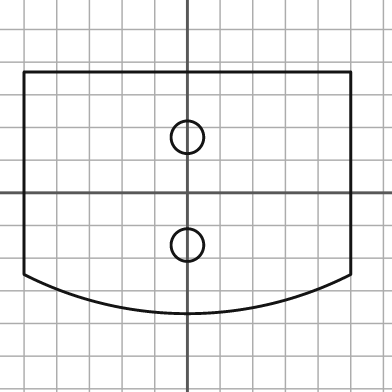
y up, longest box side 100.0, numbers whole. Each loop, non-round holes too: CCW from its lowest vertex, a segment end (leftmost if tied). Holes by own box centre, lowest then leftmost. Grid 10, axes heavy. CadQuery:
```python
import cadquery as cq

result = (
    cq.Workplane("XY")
    .moveTo(-50.0, -25.0)
    .threePointArc((0.0, -37.0), (50.0, -25.0))
    .lineTo(50.0, 37.0)
    .lineTo(-50.0, 37.0)
    .close()
    .moveTo(0.0, -16.0)
    .circle(5.0)
    .moveTo(0.0, 17.0)
    .circle(5.0)
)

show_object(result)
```